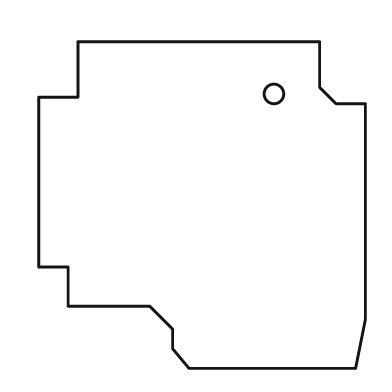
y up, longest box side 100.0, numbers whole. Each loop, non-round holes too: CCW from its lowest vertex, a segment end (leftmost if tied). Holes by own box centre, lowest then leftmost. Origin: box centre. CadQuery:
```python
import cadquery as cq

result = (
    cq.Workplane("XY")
    .moveTo(-4.0, -50.0)
    .lineTo(47.0, -50.0)
    .lineTo(50.0, -35.0)
    .lineTo(50.0, 31.0)
    .lineTo(41.0, 31.0)
    .lineTo(36.0, 36.0)
    .lineTo(36.0, 50.0)
    .lineTo(-38.0, 50.0)
    .lineTo(-38.0, 33.0)
    .lineTo(-50.0, 33.0)
    .lineTo(-50.0, -19.0)
    .lineTo(-41.0, -19.0)
    .lineTo(-41.0, -31.0)
    .lineTo(-16.0, -31.0)
    .lineTo(-9.0, -38.0)
    .lineTo(-9.0, -44.0)
    .close()
    .moveTo(22.0, 34.0)
    .circle(3.0)
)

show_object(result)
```